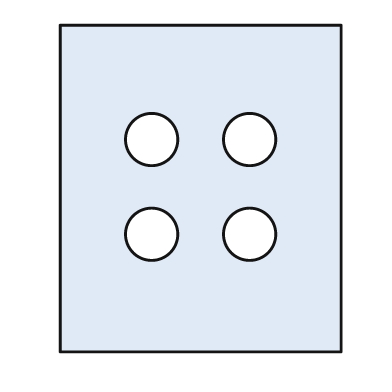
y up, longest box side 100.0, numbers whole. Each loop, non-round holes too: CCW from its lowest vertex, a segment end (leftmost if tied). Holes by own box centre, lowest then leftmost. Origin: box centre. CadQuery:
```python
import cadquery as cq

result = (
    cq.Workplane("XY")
    .moveTo(-43.0, -50.0)
    .lineTo(43.0, -50.0)
    .lineTo(43.0, 50.0)
    .lineTo(-43.0, 50.0)
    .close()
    .moveTo(-15.0, -14.0)
    .circle(8.0)
    .moveTo(15.0, -14.0)
    .circle(8.0)
    .moveTo(-15.0, 15.0)
    .circle(8.0)
    .moveTo(15.0, 15.0)
    .circle(8.0)
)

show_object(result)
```